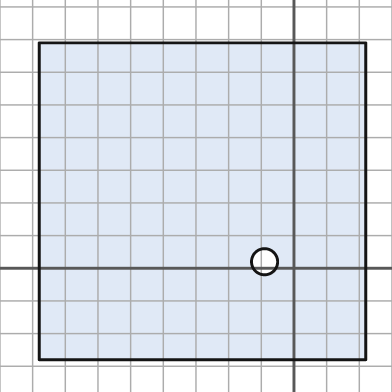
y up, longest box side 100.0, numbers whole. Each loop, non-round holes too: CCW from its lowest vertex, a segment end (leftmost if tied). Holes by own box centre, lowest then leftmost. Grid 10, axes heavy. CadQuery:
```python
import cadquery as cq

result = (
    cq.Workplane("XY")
    .moveTo(-78.0, -28.0)
    .lineTo(22.0, -28.0)
    .lineTo(22.0, 69.0)
    .lineTo(-78.0, 69.0)
    .close()
    .moveTo(-9.0, 2.0)
    .circle(4.0)
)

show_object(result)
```